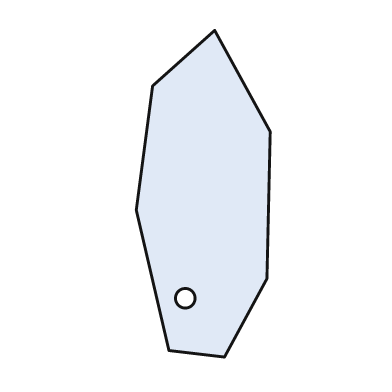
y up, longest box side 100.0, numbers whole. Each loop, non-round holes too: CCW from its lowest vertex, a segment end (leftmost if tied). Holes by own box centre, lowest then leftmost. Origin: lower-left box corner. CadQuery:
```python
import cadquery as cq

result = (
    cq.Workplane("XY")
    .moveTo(27.0, 0.0)
    .lineTo(40.0, 24.0)
    .lineTo(41.0, 69.0)
    .lineTo(24.0, 100.0)
    .lineTo(5.0, 83.0)
    .lineTo(0.0, 45.0)
    .lineTo(10.0, 2.0)
    .close()
    .moveTo(15.0, 18.0)
    .circle(3.0)
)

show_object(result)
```